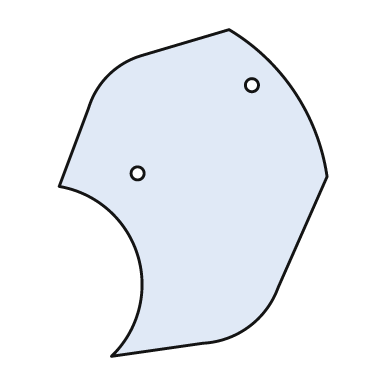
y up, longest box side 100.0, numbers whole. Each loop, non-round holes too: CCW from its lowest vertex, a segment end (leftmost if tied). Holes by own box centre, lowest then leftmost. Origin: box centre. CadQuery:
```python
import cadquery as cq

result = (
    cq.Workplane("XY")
    .moveTo(-25.0, -50.0)
    .lineTo(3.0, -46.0)
    .threePointArc((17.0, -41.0), (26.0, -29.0))
    .lineTo(41.0, 5.0)
    .threePointArc((31.0, 31.0), (11.0, 50.0))
    .lineTo(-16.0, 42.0)
    .threePointArc((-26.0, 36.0), (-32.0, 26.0))
    .lineTo(-41.0, 2.0)
    .threePointArc((-17.0, -19.0), (-25.0, -50.0))
    .close()
    .moveTo(-17.0, 6.0)
    .circle(2.0)
    .moveTo(18.0, 33.0)
    .circle(2.0)
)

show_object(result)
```